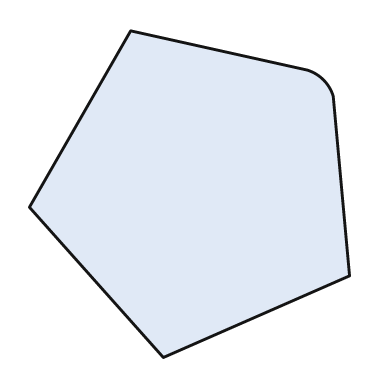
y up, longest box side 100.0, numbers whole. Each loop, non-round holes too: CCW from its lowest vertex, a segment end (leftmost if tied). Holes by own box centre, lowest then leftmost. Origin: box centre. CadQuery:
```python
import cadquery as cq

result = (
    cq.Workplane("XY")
    .moveTo(-8.0, -50.0)
    .lineTo(49.0, -25.0)
    .lineTo(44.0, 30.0)
    .threePointArc((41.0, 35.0), (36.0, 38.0))
    .lineTo(-18.0, 50.0)
    .lineTo(-49.0, -4.0)
    .close()
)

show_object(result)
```